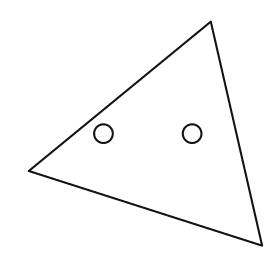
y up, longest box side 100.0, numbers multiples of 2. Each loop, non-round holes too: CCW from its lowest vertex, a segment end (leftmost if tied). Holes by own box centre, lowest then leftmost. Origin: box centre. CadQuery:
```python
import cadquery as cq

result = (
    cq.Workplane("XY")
    .moveTo(50.0, -48.0)
    .lineTo(28.0, 48.0)
    .lineTo(-50.0, -16.0)
    .close()
    .moveTo(-18.0, 0.0)
    .circle(4.0)
    .moveTo(20.0, 0.0)
    .circle(4.0)
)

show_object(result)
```